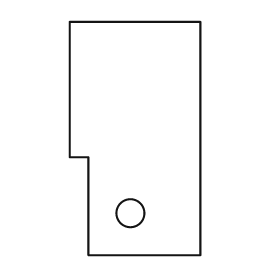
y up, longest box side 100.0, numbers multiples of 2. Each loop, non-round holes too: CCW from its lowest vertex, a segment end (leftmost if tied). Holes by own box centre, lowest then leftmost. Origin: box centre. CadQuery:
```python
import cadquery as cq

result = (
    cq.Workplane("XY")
    .moveTo(-20.0, -50.0)
    .lineTo(28.0, -50.0)
    .lineTo(28.0, 50.0)
    .lineTo(-28.0, 50.0)
    .lineTo(-28.0, -8.0)
    .lineTo(-20.0, -8.0)
    .close()
    .moveTo(-2.0, -32.0)
    .circle(6.0)
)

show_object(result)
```